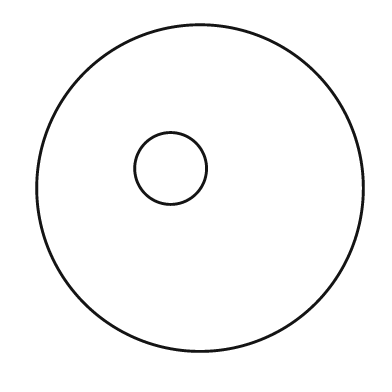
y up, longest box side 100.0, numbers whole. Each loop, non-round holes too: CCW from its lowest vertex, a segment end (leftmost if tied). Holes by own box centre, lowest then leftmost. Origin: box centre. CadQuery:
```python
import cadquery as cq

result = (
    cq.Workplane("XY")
    .moveTo(0.0, 0.0)
    .circle(50.0)
    .moveTo(-9.0, 6.0)
    .circle(11.0)
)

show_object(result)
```